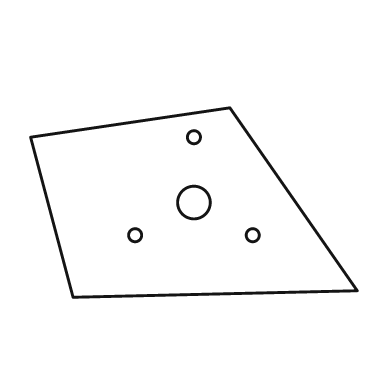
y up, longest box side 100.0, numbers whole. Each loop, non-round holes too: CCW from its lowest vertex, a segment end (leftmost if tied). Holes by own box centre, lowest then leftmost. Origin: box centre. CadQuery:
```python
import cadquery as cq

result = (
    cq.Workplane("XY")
    .moveTo(-37.0, -29.0)
    .lineTo(50.0, -27.0)
    .lineTo(11.0, 29.0)
    .lineTo(-50.0, 20.0)
    .close()
    .moveTo(-18.0, -10.0)
    .circle(2.0)
    .moveTo(18.0, -10.0)
    .circle(2.0)
    .moveTo(0.0, 0.0)
    .circle(5.0)
    .moveTo(0.0, 20.0)
    .circle(2.0)
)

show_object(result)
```